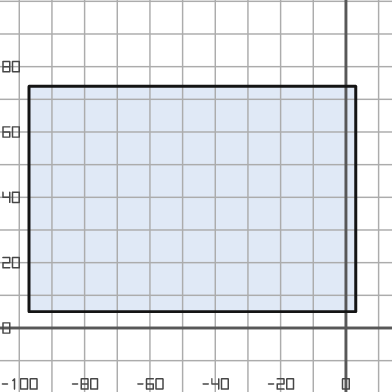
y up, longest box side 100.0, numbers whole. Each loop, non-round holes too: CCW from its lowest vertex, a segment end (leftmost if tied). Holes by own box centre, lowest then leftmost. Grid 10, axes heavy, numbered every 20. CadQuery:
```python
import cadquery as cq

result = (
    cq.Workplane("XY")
    .moveTo(-97.0, 5.0)
    .lineTo(3.0, 5.0)
    .lineTo(3.0, 74.0)
    .lineTo(-97.0, 74.0)
    .close()
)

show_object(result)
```